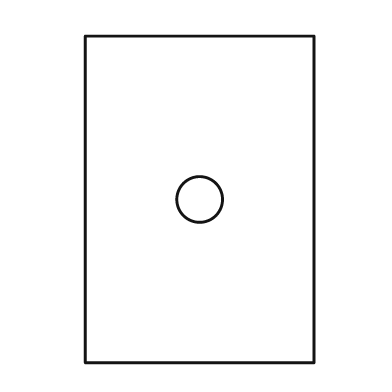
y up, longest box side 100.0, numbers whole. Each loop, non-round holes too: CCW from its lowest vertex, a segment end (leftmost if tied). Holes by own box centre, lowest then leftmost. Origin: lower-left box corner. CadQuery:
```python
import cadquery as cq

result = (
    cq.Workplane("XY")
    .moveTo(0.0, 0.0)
    .lineTo(70.0, 0.0)
    .lineTo(70.0, 100.0)
    .lineTo(0.0, 100.0)
    .close()
    .moveTo(35.0, 50.0)
    .circle(7.0)
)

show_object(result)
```